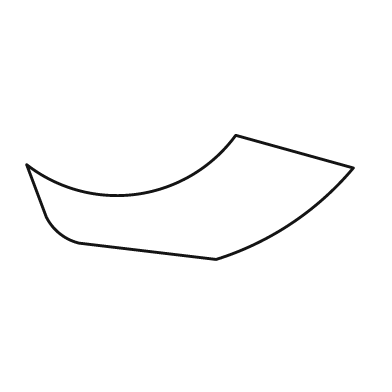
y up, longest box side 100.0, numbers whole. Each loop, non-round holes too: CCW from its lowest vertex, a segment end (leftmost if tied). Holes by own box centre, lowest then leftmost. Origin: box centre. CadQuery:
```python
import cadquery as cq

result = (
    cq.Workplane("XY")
    .moveTo(8.0, -19.0)
    .threePointArc((31.0, -8.0), (50.0, 9.0))
    .lineTo(14.0, 19.0)
    .threePointArc((-16.0, 1.0), (-50.0, 10.0))
    .lineTo(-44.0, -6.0)
    .threePointArc((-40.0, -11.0), (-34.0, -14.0))
    .close()
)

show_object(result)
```